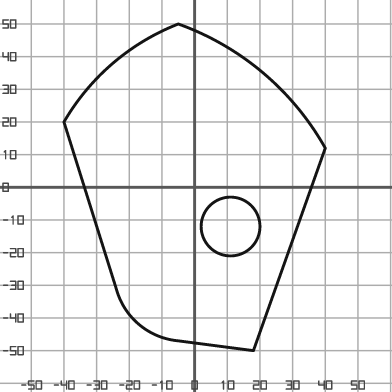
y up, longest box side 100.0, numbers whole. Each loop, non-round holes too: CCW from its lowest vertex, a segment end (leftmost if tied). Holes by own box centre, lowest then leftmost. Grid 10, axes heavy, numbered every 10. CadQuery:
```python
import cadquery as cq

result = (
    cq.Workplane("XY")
    .moveTo(18.0, -50.0)
    .lineTo(40.0, 12.0)
    .threePointArc((21.0, 35.0), (-5.0, 50.0))
    .threePointArc((-25.0, 38.0), (-40.0, 20.0))
    .lineTo(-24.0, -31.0)
    .threePointArc((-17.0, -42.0), (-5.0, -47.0))
    .close()
    .moveTo(11.0, -12.0)
    .circle(9.0)
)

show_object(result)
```